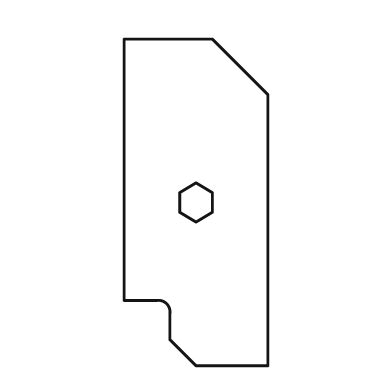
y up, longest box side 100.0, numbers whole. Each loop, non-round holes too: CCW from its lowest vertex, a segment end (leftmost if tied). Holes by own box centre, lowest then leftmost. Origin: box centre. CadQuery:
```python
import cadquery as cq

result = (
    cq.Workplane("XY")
    .moveTo(0.0, -50.0)
    .lineTo(22.0, -50.0)
    .lineTo(22.0, 33.0)
    .lineTo(5.0, 50.0)
    .lineTo(-22.0, 50.0)
    .lineTo(-22.0, -30.0)
    .lineTo(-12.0, -30.0)
    .threePointArc((-9.0, -31.0), (-8.0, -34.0))
    .lineTo(-8.0, -42.0)
    .close()
    .moveTo(0.0, -6.0)
    .lineTo(5.0, -3.0)
    .lineTo(5.0, 3.0)
    .lineTo(0.0, 6.0)
    .lineTo(-5.0, 3.0)
    .lineTo(-5.0, -3.0)
    .close()
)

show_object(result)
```